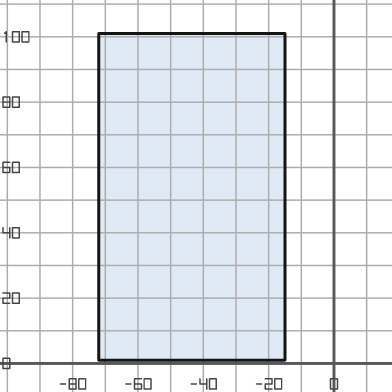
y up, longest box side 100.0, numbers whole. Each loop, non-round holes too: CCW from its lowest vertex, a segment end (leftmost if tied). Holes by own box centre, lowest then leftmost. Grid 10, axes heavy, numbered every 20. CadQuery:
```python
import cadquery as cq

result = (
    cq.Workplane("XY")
    .moveTo(-72.0, 1.0)
    .lineTo(-15.0, 1.0)
    .lineTo(-15.0, 101.0)
    .lineTo(-72.0, 101.0)
    .close()
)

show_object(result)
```